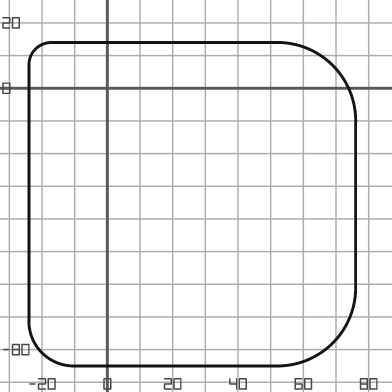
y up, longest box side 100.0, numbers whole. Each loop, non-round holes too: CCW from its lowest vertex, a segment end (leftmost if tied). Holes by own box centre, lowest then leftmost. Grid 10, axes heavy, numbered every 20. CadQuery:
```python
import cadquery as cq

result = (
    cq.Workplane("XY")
    .moveTo(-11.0, -85.0)
    .lineTo(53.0, -85.0)
    .threePointArc((69.0, -78.0), (76.0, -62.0))
    .lineTo(76.0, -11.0)
    .threePointArc((69.0, 7.0), (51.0, 14.0))
    .lineTo(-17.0, 14.0)
    .threePointArc((-22.0, 12.0), (-24.0, 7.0))
    .lineTo(-24.0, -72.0)
    .threePointArc((-20.0, -81.0), (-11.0, -85.0))
    .close()
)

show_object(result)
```